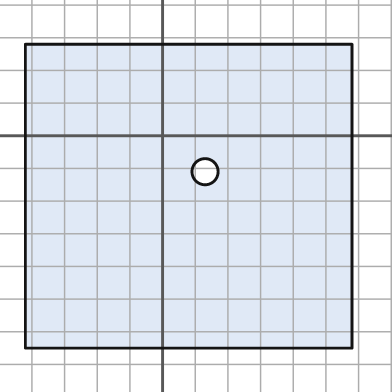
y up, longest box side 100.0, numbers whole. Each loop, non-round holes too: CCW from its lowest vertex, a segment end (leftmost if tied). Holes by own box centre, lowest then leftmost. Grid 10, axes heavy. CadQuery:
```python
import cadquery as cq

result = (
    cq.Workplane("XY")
    .moveTo(-42.0, -65.0)
    .lineTo(58.0, -65.0)
    .lineTo(58.0, 28.0)
    .lineTo(-42.0, 28.0)
    .close()
    .moveTo(13.0, -11.0)
    .circle(4.0)
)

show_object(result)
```